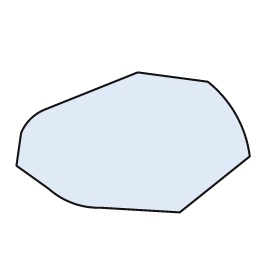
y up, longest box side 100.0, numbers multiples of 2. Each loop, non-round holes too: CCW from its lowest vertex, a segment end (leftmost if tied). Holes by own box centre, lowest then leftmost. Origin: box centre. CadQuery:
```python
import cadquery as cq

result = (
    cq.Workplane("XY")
    .moveTo(20.0, -30.0)
    .lineTo(50.0, -6.0)
    .threePointArc((44.0, 12.0), (32.0, 26.0))
    .lineTo(2.0, 30.0)
    .lineTo(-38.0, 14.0)
    .threePointArc((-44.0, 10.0), (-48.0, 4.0))
    .lineTo(-50.0, -10.0)
    .lineTo(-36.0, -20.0)
    .threePointArc((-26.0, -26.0), (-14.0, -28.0))
    .close()
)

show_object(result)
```